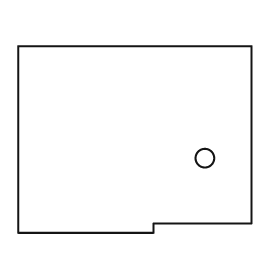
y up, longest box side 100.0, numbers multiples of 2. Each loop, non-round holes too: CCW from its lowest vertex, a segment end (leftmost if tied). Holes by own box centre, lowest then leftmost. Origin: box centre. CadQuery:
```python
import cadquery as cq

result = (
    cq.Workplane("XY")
    .moveTo(-50.0, -40.0)
    .lineTo(8.0, -40.0)
    .lineTo(8.0, -36.0)
    .lineTo(50.0, -36.0)
    .lineTo(50.0, 40.0)
    .lineTo(-50.0, 40.0)
    .close()
    .moveTo(30.0, -8.0)
    .circle(4.0)
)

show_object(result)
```